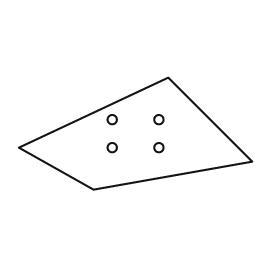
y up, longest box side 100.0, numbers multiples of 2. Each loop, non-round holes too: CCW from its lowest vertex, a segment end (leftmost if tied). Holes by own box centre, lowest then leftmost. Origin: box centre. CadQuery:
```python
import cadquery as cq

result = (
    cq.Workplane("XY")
    .moveTo(-18.0, -24.0)
    .lineTo(50.0, -12.0)
    .lineTo(14.0, 24.0)
    .lineTo(-50.0, -6.0)
    .close()
    .moveTo(-10.0, -6.0)
    .circle(2.0)
    .moveTo(10.0, -6.0)
    .circle(2.0)
    .moveTo(-10.0, 6.0)
    .circle(2.0)
    .moveTo(10.0, 6.0)
    .circle(2.0)
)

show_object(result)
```